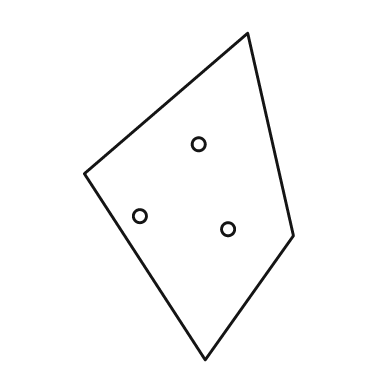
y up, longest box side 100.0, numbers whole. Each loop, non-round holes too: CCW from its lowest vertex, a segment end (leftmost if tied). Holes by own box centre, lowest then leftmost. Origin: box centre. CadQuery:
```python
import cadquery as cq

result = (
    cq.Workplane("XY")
    .moveTo(5.0, -50.0)
    .lineTo(32.0, -12.0)
    .lineTo(18.0, 50.0)
    .lineTo(-32.0, 7.0)
    .close()
    .moveTo(12.0, -10.0)
    .circle(2.0)
    .moveTo(-15.0, -6.0)
    .circle(2.0)
    .moveTo(3.0, 16.0)
    .circle(2.0)
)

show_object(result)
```